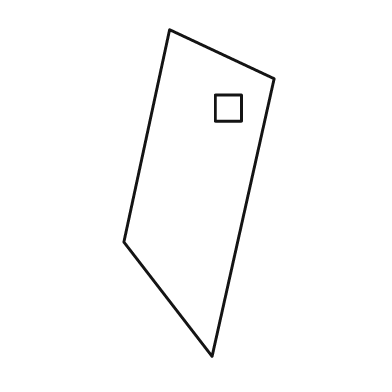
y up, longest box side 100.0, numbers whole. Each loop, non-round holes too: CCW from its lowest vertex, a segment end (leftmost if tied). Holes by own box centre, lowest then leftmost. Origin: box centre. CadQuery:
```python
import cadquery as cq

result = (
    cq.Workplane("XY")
    .moveTo(4.0, -50.0)
    .lineTo(23.0, 35.0)
    .lineTo(-9.0, 50.0)
    .lineTo(-23.0, -15.0)
    .close()
    .moveTo(5.0, 22.0)
    .lineTo(13.0, 22.0)
    .lineTo(13.0, 30.0)
    .lineTo(5.0, 30.0)
    .close()
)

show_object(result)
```